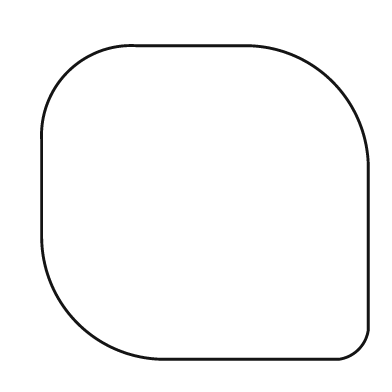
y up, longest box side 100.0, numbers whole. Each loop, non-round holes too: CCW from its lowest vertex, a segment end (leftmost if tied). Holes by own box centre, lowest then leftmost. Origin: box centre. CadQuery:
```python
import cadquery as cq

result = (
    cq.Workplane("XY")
    .moveTo(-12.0, -48.0)
    .lineTo(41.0, -48.0)
    .threePointArc((47.0, -45.0), (50.0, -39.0))
    .lineTo(50.0, 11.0)
    .threePointArc((39.0, 37.0), (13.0, 48.0))
    .lineTo(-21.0, 48.0)
    .threePointArc((-42.0, 40.0), (-50.0, 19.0))
    .lineTo(-50.0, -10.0)
    .threePointArc((-39.0, -37.0), (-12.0, -48.0))
    .close()
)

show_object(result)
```